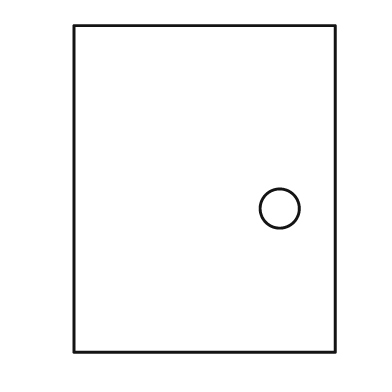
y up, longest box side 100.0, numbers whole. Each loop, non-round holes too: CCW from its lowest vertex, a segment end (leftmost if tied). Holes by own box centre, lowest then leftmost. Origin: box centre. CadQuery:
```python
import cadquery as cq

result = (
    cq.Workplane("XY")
    .moveTo(-40.0, -50.0)
    .lineTo(40.0, -50.0)
    .lineTo(40.0, 50.0)
    .lineTo(-40.0, 50.0)
    .close()
    .moveTo(23.0, -6.0)
    .circle(6.0)
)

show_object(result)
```